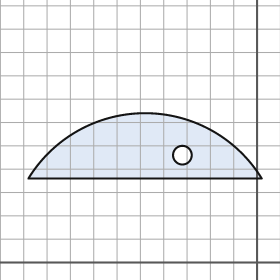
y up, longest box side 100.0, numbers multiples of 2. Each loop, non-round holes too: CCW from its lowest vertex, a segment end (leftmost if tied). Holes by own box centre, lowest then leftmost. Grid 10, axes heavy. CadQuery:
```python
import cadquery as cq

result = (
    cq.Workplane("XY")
    .moveTo(-98.0, 36.0)
    .lineTo(2.0, 36.0)
    .threePointArc((-48.0, 64.0), (-98.0, 36.0))
    .close()
    .moveTo(-32.0, 46.0)
    .circle(4.0)
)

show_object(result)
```